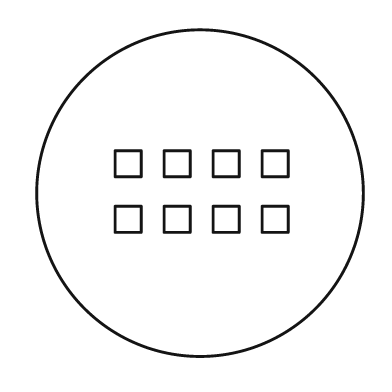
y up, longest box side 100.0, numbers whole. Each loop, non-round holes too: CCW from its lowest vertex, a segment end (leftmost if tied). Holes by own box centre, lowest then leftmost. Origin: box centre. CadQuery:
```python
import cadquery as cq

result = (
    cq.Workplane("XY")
    .moveTo(0.0, 0.0)
    .circle(50.0)
    .moveTo(-26.0, -12.0)
    .lineTo(-18.0, -12.0)
    .lineTo(-18.0, -4.0)
    .lineTo(-26.0, -4.0)
    .close()
    .moveTo(-11.0, -12.0)
    .lineTo(-3.0, -12.0)
    .lineTo(-3.0, -4.0)
    .lineTo(-11.0, -4.0)
    .close()
    .moveTo(4.0, -12.0)
    .lineTo(12.0, -12.0)
    .lineTo(12.0, -4.0)
    .lineTo(4.0, -4.0)
    .close()
    .moveTo(19.0, -12.0)
    .lineTo(27.0, -12.0)
    .lineTo(27.0, -4.0)
    .lineTo(19.0, -4.0)
    .close()
    .moveTo(-26.0, 5.0)
    .lineTo(-18.0, 5.0)
    .lineTo(-18.0, 13.0)
    .lineTo(-26.0, 13.0)
    .close()
    .moveTo(-11.0, 5.0)
    .lineTo(-3.0, 5.0)
    .lineTo(-3.0, 13.0)
    .lineTo(-11.0, 13.0)
    .close()
    .moveTo(4.0, 5.0)
    .lineTo(12.0, 5.0)
    .lineTo(12.0, 13.0)
    .lineTo(4.0, 13.0)
    .close()
    .moveTo(19.0, 5.0)
    .lineTo(27.0, 5.0)
    .lineTo(27.0, 13.0)
    .lineTo(19.0, 13.0)
    .close()
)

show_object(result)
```